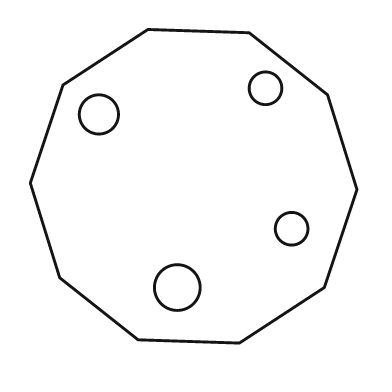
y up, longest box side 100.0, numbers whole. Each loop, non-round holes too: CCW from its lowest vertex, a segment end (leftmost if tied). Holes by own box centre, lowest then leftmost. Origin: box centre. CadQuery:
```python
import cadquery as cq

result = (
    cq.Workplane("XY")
    .moveTo(14.0, -48.0)
    .lineTo(40.0, -31.0)
    .lineTo(50.0, -1.0)
    .lineTo(41.0, 28.0)
    .lineTo(17.0, 47.0)
    .lineTo(-14.0, 48.0)
    .lineTo(-40.0, 31.0)
    .lineTo(-50.0, 1.0)
    .lineTo(-41.0, -28.0)
    .lineTo(-17.0, -47.0)
    .close()
    .moveTo(-5.0, -31.0)
    .circle(7.0)
    .moveTo(30.0, -13.0)
    .circle(5.0)
    .moveTo(-29.0, 22.0)
    .circle(6.0)
    .moveTo(22.0, 30.0)
    .circle(5.0)
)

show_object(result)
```